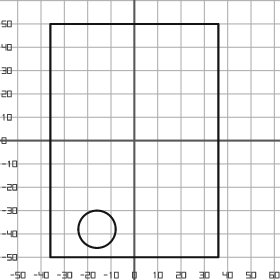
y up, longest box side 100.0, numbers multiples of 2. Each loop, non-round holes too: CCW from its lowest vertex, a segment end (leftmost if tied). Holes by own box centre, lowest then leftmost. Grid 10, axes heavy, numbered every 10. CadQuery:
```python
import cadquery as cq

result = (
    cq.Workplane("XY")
    .moveTo(-36.0, -50.0)
    .lineTo(36.0, -50.0)
    .lineTo(36.0, 50.0)
    .lineTo(-36.0, 50.0)
    .close()
    .moveTo(-16.0, -38.0)
    .circle(8.0)
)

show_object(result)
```